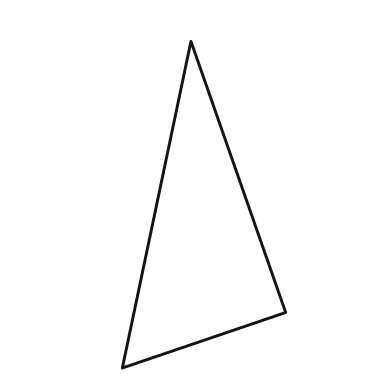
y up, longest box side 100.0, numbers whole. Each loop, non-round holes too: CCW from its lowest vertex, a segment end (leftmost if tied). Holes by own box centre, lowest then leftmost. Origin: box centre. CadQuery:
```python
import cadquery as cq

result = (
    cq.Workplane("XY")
    .moveTo(-25.0, -50.0)
    .lineTo(25.0, -33.0)
    .lineTo(-4.0, 50.0)
    .close()
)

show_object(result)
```